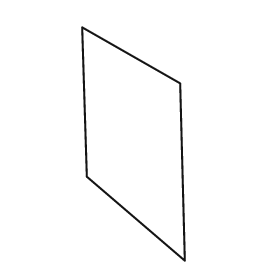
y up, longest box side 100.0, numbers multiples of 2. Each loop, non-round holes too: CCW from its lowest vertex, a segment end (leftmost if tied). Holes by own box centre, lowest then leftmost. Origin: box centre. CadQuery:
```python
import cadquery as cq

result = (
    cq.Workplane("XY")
    .moveTo(22.0, -50.0)
    .lineTo(20.0, 26.0)
    .lineTo(-22.0, 50.0)
    .lineTo(-20.0, -14.0)
    .close()
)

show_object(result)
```